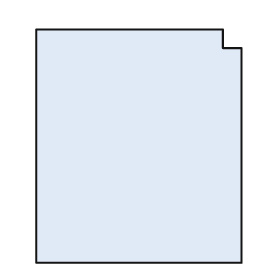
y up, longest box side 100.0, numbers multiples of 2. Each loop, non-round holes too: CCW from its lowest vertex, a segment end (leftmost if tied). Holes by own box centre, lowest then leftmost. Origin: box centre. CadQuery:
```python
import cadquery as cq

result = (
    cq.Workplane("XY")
    .moveTo(-44.0, -50.0)
    .lineTo(44.0, -50.0)
    .lineTo(44.0, 42.0)
    .lineTo(36.0, 42.0)
    .lineTo(36.0, 50.0)
    .lineTo(-44.0, 50.0)
    .close()
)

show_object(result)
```